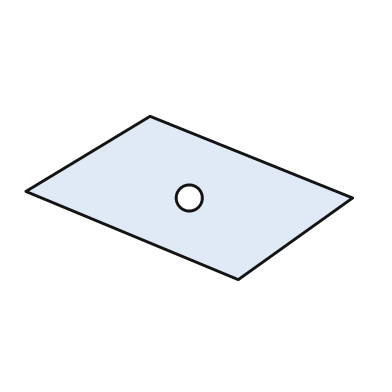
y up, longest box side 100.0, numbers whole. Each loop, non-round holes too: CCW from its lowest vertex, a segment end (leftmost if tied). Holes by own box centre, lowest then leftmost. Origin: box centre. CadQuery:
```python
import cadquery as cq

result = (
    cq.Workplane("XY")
    .moveTo(15.0, -25.0)
    .lineTo(50.0, 0.0)
    .lineTo(-12.0, 25.0)
    .lineTo(-50.0, 2.0)
    .close()
    .moveTo(0.0, 0.0)
    .circle(4.0)
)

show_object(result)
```